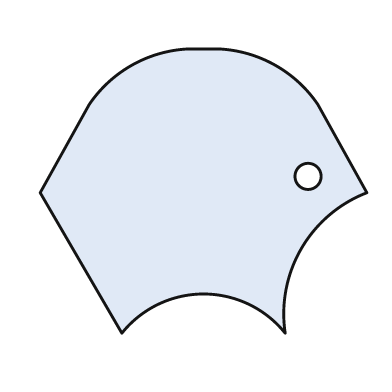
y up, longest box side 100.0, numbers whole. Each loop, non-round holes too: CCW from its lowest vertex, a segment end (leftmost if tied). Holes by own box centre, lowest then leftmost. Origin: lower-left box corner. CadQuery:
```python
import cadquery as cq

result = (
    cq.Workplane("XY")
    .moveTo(25.0, 0.0)
    .threePointArc((50.0, 12.0), (75.0, 0.0))
    .threePointArc((80.0, 26.0), (100.0, 43.0))
    .lineTo(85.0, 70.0)
    .threePointArc((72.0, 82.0), (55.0, 87.0))
    .lineTo(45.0, 87.0)
    .threePointArc((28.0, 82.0), (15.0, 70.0))
    .lineTo(0.0, 43.0)
    .close()
    .moveTo(82.0, 48.0)
    .circle(4.0)
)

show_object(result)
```